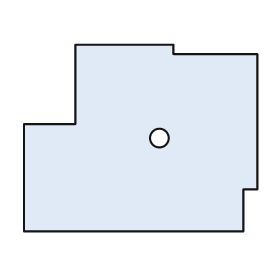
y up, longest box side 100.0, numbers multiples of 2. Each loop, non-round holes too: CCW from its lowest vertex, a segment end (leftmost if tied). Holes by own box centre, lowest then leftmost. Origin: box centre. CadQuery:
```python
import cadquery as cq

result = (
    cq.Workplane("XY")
    .moveTo(-50.0, -40.0)
    .lineTo(44.0, -40.0)
    .lineTo(44.0, -22.0)
    .lineTo(50.0, -22.0)
    .lineTo(50.0, 36.0)
    .lineTo(14.0, 36.0)
    .lineTo(14.0, 40.0)
    .lineTo(-28.0, 40.0)
    .lineTo(-28.0, 6.0)
    .lineTo(-50.0, 6.0)
    .close()
    .moveTo(8.0, 0.0)
    .circle(4.0)
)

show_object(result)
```